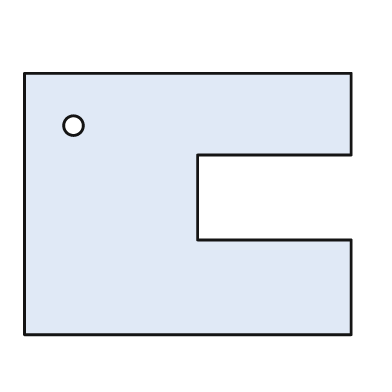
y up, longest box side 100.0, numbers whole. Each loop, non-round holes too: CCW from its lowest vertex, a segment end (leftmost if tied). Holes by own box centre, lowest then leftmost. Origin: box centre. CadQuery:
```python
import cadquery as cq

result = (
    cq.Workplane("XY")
    .moveTo(-50.0, -40.0)
    .lineTo(50.0, -40.0)
    .lineTo(50.0, -11.0)
    .lineTo(3.0, -11.0)
    .lineTo(3.0, 15.0)
    .lineTo(50.0, 15.0)
    .lineTo(50.0, 40.0)
    .lineTo(-50.0, 40.0)
    .close()
    .moveTo(-35.0, 24.0)
    .circle(3.0)
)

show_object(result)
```